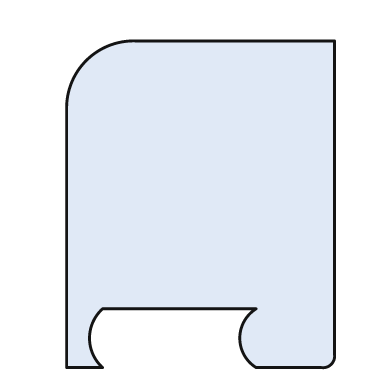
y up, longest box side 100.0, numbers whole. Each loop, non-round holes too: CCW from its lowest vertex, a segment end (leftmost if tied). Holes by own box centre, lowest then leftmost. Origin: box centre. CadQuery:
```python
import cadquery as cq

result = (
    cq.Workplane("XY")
    .moveTo(-41.0, -50.0)
    .lineTo(-30.0, -50.0)
    .threePointArc((-34.0, -41.0), (-30.0, -32.0))
    .lineTo(17.0, -32.0)
    .threePointArc((12.0, -41.0), (17.0, -50.0))
    .lineTo(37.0, -50.0)
    .threePointArc((40.0, -49.0), (41.0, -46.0))
    .lineTo(41.0, 50.0)
    .lineTo(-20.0, 50.0)
    .threePointArc((-35.0, 44.0), (-41.0, 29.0))
    .close()
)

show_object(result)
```